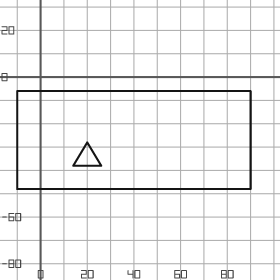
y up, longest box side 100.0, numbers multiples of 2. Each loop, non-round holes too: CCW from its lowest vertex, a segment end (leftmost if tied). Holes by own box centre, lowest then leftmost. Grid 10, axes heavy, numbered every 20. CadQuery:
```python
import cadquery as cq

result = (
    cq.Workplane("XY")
    .moveTo(-10.0, -48.0)
    .lineTo(90.0, -48.0)
    .lineTo(90.0, -6.0)
    .lineTo(-10.0, -6.0)
    .close()
    .moveTo(14.0, -38.0)
    .lineTo(26.0, -38.0)
    .lineTo(20.0, -28.0)
    .close()
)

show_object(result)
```